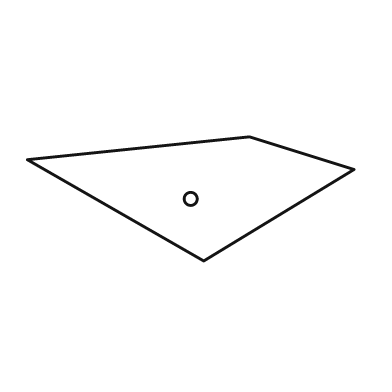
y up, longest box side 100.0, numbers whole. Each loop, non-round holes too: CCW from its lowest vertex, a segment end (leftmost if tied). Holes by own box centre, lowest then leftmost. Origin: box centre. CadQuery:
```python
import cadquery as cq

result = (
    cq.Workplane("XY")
    .moveTo(4.0, -19.0)
    .lineTo(50.0, 9.0)
    .lineTo(18.0, 19.0)
    .lineTo(-50.0, 12.0)
    .close()
    .moveTo(0.0, 0.0)
    .circle(2.0)
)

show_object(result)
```